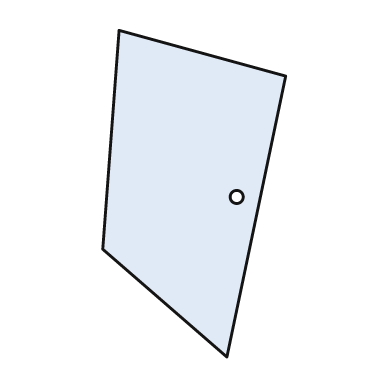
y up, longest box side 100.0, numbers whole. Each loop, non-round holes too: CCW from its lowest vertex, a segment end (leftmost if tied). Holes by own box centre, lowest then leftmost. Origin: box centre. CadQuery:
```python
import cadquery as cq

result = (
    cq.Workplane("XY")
    .moveTo(10.0, -50.0)
    .lineTo(28.0, 36.0)
    .lineTo(-23.0, 50.0)
    .lineTo(-28.0, -17.0)
    .close()
    .moveTo(13.0, -1.0)
    .circle(2.0)
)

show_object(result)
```